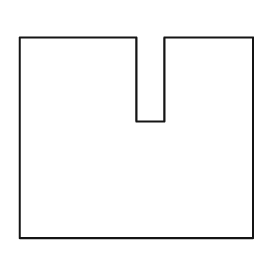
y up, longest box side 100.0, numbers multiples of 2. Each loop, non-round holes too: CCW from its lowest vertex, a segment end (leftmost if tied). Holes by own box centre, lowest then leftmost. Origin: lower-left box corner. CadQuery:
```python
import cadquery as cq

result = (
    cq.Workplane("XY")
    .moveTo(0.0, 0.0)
    .lineTo(100.0, 0.0)
    .lineTo(100.0, 86.0)
    .lineTo(62.0, 86.0)
    .lineTo(62.0, 50.0)
    .lineTo(50.0, 50.0)
    .lineTo(50.0, 86.0)
    .lineTo(0.0, 86.0)
    .close()
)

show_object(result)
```